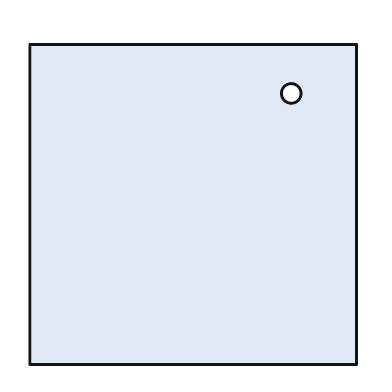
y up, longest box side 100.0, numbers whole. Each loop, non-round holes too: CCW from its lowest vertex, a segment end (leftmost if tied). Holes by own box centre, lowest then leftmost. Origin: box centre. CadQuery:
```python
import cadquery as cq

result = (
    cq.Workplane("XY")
    .moveTo(-50.0, -49.0)
    .lineTo(50.0, -49.0)
    .lineTo(50.0, 49.0)
    .lineTo(-50.0, 49.0)
    .close()
    .moveTo(30.0, 34.0)
    .circle(3.0)
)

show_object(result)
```